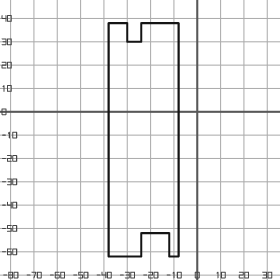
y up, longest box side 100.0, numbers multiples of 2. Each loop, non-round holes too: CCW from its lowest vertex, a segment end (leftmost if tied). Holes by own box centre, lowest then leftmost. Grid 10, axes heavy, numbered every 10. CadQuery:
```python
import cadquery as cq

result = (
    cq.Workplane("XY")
    .moveTo(-38.0, -62.0)
    .lineTo(-24.0, -62.0)
    .lineTo(-24.0, -52.0)
    .lineTo(-12.0, -52.0)
    .lineTo(-12.0, -62.0)
    .lineTo(-8.0, -62.0)
    .lineTo(-8.0, 38.0)
    .lineTo(-24.0, 38.0)
    .lineTo(-24.0, 30.0)
    .lineTo(-30.0, 30.0)
    .lineTo(-30.0, 38.0)
    .lineTo(-38.0, 38.0)
    .close()
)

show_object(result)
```